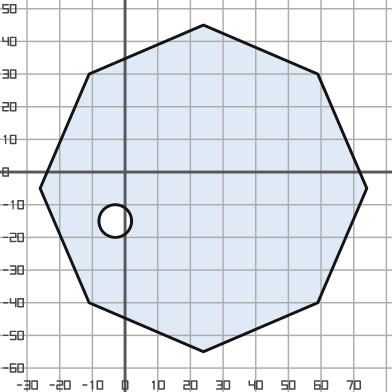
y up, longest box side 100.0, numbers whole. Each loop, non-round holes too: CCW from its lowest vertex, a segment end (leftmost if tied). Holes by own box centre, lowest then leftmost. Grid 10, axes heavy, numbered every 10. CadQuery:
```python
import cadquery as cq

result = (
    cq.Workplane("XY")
    .moveTo(24.0, -55.0)
    .lineTo(59.0, -40.0)
    .lineTo(74.0, -5.0)
    .lineTo(59.0, 30.0)
    .lineTo(24.0, 45.0)
    .lineTo(-11.0, 30.0)
    .lineTo(-26.0, -5.0)
    .lineTo(-11.0, -40.0)
    .close()
    .moveTo(-3.0, -15.0)
    .circle(5.0)
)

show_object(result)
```